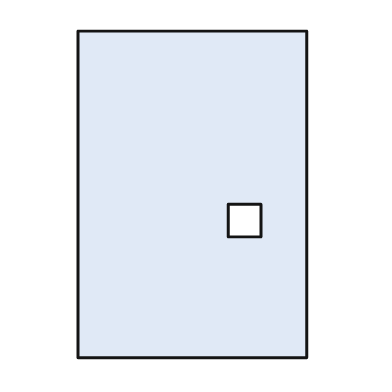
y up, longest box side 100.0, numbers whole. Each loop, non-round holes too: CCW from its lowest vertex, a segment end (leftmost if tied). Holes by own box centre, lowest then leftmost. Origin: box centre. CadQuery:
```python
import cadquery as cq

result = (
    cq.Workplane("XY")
    .moveTo(-35.0, -50.0)
    .lineTo(35.0, -50.0)
    .lineTo(35.0, 50.0)
    .lineTo(-35.0, 50.0)
    .close()
    .moveTo(11.0, -13.0)
    .lineTo(21.0, -13.0)
    .lineTo(21.0, -3.0)
    .lineTo(11.0, -3.0)
    .close()
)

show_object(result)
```